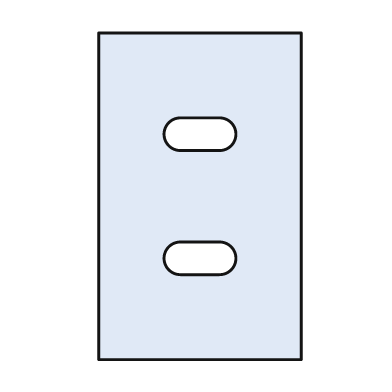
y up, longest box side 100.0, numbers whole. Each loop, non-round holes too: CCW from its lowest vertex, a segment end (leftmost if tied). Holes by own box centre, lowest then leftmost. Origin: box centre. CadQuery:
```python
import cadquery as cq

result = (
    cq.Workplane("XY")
    .moveTo(-31.0, -50.0)
    .lineTo(31.0, -50.0)
    .lineTo(31.0, 50.0)
    .lineTo(-31.0, 50.0)
    .close()
    .moveTo(-6.0, -24.0)
    .lineTo(6.0, -24.0)
    .threePointArc((11.0, -19.0), (6.0, -14.0))
    .lineTo(-6.0, -14.0)
    .threePointArc((-11.0, -19.0), (-6.0, -24.0))
    .close()
    .moveTo(-6.0, 14.0)
    .lineTo(6.0, 14.0)
    .threePointArc((11.0, 19.0), (6.0, 24.0))
    .lineTo(-6.0, 24.0)
    .threePointArc((-11.0, 19.0), (-6.0, 14.0))
    .close()
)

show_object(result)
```